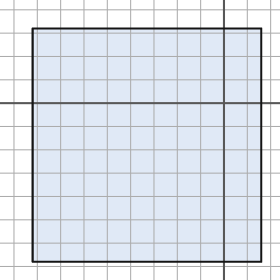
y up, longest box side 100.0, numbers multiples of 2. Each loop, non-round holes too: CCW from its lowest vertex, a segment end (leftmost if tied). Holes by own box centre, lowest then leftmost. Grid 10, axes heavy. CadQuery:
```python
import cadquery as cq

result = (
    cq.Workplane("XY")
    .moveTo(-82.0, -68.0)
    .lineTo(16.0, -68.0)
    .lineTo(16.0, 32.0)
    .lineTo(-82.0, 32.0)
    .close()
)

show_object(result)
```